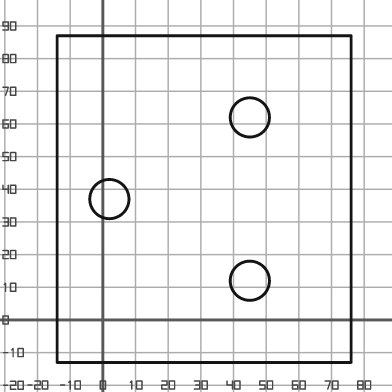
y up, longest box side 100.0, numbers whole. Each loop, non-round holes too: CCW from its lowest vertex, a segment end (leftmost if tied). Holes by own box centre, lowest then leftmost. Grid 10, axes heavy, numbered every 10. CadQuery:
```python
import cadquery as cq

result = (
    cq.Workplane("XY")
    .moveTo(-14.0, -13.0)
    .lineTo(76.0, -13.0)
    .lineTo(76.0, 87.0)
    .lineTo(-14.0, 87.0)
    .close()
    .moveTo(45.0, 12.0)
    .circle(6.0)
    .moveTo(2.0, 37.0)
    .circle(6.0)
    .moveTo(45.0, 62.0)
    .circle(6.0)
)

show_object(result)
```